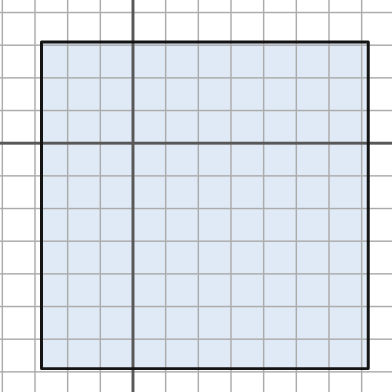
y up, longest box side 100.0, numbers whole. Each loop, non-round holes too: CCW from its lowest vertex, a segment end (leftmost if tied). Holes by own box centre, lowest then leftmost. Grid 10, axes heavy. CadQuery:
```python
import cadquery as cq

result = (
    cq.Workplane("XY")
    .moveTo(-28.0, -69.0)
    .lineTo(72.0, -69.0)
    .lineTo(72.0, 31.0)
    .lineTo(-28.0, 31.0)
    .close()
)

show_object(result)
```